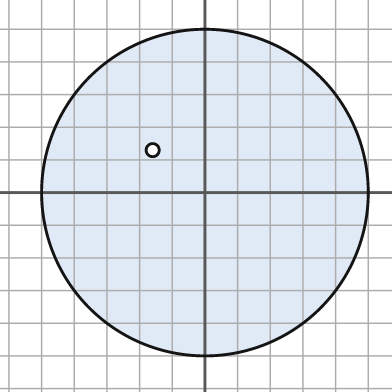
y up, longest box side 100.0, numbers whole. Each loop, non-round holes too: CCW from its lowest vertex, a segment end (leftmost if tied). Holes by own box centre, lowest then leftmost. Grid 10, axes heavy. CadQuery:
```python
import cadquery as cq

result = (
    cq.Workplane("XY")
    .moveTo(0.0, 0.0)
    .circle(50.0)
    .moveTo(-16.0, 13.0)
    .circle(2.0)
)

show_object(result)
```